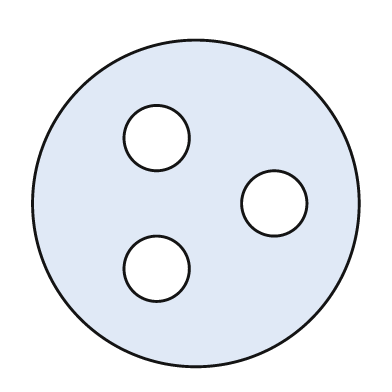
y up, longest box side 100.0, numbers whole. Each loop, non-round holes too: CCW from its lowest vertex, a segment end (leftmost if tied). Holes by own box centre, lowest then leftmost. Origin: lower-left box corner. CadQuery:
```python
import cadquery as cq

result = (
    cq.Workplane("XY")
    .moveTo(50.0, 50.0)
    .circle(50.0)
    .moveTo(38.0, 30.0)
    .circle(10.0)
    .moveTo(74.0, 50.0)
    .circle(10.0)
    .moveTo(38.0, 70.0)
    .circle(10.0)
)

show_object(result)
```